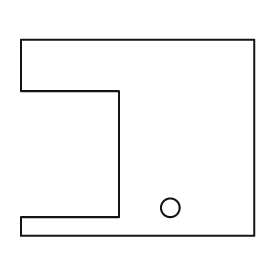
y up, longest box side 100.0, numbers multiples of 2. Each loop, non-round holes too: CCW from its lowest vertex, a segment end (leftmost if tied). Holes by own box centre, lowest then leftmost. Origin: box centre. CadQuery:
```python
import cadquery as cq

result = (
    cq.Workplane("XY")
    .moveTo(-50.0, -42.0)
    .lineTo(50.0, -42.0)
    .lineTo(50.0, 42.0)
    .lineTo(-50.0, 42.0)
    .lineTo(-50.0, 20.0)
    .lineTo(-8.0, 20.0)
    .lineTo(-8.0, -34.0)
    .lineTo(-50.0, -34.0)
    .close()
    .moveTo(14.0, -30.0)
    .circle(4.0)
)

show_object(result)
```